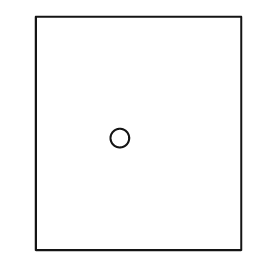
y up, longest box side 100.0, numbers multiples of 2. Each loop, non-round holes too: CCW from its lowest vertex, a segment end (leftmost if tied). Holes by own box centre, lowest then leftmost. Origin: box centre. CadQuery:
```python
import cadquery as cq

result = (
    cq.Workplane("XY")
    .moveTo(-44.0, -50.0)
    .lineTo(44.0, -50.0)
    .lineTo(44.0, 50.0)
    .lineTo(-44.0, 50.0)
    .close()
    .moveTo(-8.0, -2.0)
    .circle(4.0)
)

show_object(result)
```